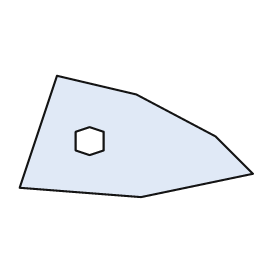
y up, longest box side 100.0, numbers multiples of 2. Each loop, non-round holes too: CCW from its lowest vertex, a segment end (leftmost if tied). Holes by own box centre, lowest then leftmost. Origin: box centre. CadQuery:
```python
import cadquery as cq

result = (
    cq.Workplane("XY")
    .moveTo(2.0, -26.0)
    .lineTo(50.0, -16.0)
    .lineTo(34.0, 0.0)
    .lineTo(0.0, 18.0)
    .lineTo(-34.0, 26.0)
    .lineTo(-50.0, -22.0)
    .close()
    .moveTo(-20.0, -8.0)
    .lineTo(-14.0, -6.0)
    .lineTo(-14.0, 2.0)
    .lineTo(-20.0, 4.0)
    .lineTo(-26.0, 2.0)
    .lineTo(-26.0, -6.0)
    .close()
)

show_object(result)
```